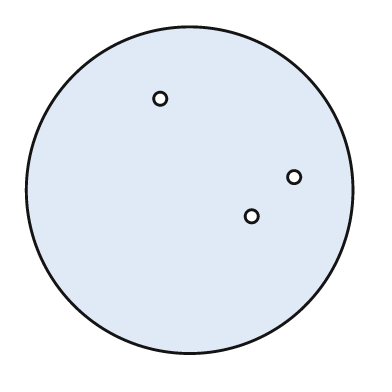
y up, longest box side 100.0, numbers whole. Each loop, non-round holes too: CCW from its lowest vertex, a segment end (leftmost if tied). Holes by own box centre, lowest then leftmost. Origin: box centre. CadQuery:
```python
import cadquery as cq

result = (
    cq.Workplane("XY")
    .moveTo(0.0, 0.0)
    .circle(50.0)
    .moveTo(19.0, -8.0)
    .circle(2.0)
    .moveTo(32.0, 4.0)
    .circle(2.0)
    .moveTo(-9.0, 28.0)
    .circle(2.0)
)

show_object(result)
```